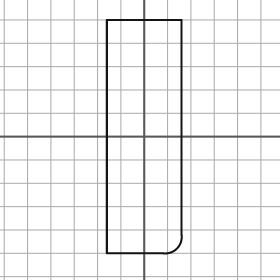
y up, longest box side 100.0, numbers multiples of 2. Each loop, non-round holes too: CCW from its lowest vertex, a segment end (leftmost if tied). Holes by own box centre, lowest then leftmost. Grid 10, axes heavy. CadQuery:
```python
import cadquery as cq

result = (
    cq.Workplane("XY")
    .moveTo(-16.0, -50.0)
    .lineTo(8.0, -50.0)
    .threePointArc((14.0, -48.0), (16.0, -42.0))
    .lineTo(16.0, 50.0)
    .lineTo(-16.0, 50.0)
    .close()
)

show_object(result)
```